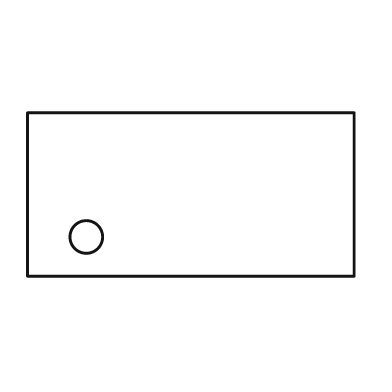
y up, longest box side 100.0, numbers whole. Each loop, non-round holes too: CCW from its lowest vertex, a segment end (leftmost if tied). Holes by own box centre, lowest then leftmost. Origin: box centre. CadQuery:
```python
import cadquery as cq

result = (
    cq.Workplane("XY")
    .moveTo(-50.0, -25.0)
    .lineTo(50.0, -25.0)
    .lineTo(50.0, 25.0)
    .lineTo(-50.0, 25.0)
    .close()
    .moveTo(-32.0, -13.0)
    .circle(5.0)
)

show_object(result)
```